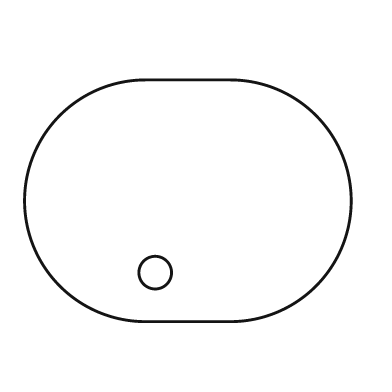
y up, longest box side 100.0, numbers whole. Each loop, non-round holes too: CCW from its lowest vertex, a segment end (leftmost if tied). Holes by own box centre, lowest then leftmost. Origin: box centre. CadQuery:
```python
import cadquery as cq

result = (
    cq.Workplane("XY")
    .moveTo(-13.0, -37.0)
    .lineTo(13.0, -37.0)
    .threePointArc((50.0, 0.0), (13.0, 37.0))
    .lineTo(-13.0, 37.0)
    .threePointArc((-50.0, 0.0), (-13.0, -37.0))
    .close()
    .moveTo(-10.0, -22.0)
    .circle(5.0)
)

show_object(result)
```